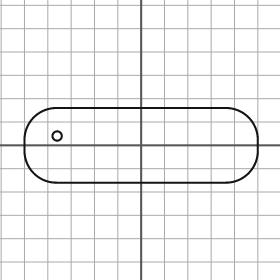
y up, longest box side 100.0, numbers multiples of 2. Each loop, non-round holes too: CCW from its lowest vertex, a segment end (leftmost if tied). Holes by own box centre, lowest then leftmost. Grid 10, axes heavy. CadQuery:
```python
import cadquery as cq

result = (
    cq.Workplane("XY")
    .moveTo(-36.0, -16.0)
    .lineTo(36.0, -16.0)
    .threePointArc((46.0, -12.0), (50.0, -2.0))
    .lineTo(50.0, 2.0)
    .threePointArc((46.0, 12.0), (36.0, 16.0))
    .lineTo(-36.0, 16.0)
    .threePointArc((-46.0, 12.0), (-50.0, 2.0))
    .lineTo(-50.0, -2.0)
    .threePointArc((-46.0, -12.0), (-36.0, -16.0))
    .close()
    .moveTo(-36.0, 4.0)
    .circle(2.0)
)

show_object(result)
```